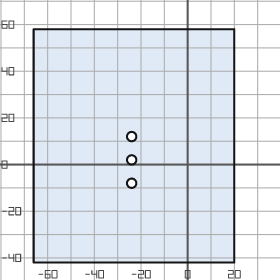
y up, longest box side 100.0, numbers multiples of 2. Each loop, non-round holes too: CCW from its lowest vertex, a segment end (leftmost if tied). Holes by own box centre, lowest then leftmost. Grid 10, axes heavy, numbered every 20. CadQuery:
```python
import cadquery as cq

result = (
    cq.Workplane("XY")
    .moveTo(-66.0, -42.0)
    .lineTo(20.0, -42.0)
    .lineTo(20.0, 58.0)
    .lineTo(-66.0, 58.0)
    .close()
    .moveTo(-24.0, -8.0)
    .circle(2.0)
    .moveTo(-24.0, 2.0)
    .circle(2.0)
    .moveTo(-24.0, 12.0)
    .circle(2.0)
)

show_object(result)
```